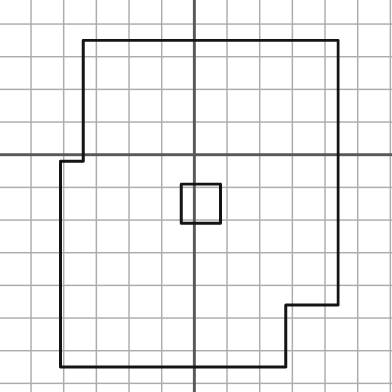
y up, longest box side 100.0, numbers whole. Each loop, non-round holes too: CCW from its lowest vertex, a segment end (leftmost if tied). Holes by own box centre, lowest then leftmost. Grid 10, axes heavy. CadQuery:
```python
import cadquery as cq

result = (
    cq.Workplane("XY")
    .moveTo(-41.0, -65.0)
    .lineTo(28.0, -65.0)
    .lineTo(28.0, -46.0)
    .lineTo(44.0, -46.0)
    .lineTo(44.0, 35.0)
    .lineTo(-34.0, 35.0)
    .lineTo(-34.0, -2.0)
    .lineTo(-41.0, -2.0)
    .close()
    .moveTo(-4.0, -21.0)
    .lineTo(8.0, -21.0)
    .lineTo(8.0, -9.0)
    .lineTo(-4.0, -9.0)
    .close()
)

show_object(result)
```